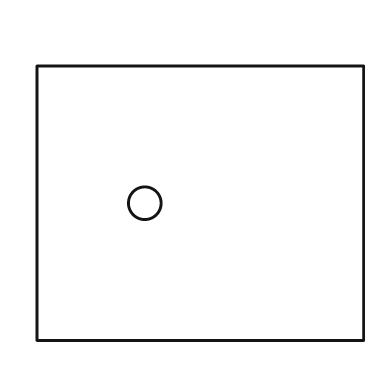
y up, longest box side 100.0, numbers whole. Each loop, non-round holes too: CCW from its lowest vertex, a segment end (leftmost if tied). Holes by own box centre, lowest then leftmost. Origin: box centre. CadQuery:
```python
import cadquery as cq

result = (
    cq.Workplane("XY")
    .moveTo(-50.0, -42.0)
    .lineTo(50.0, -42.0)
    .lineTo(50.0, 42.0)
    .lineTo(-50.0, 42.0)
    .close()
    .moveTo(-17.0, 0.0)
    .circle(5.0)
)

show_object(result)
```